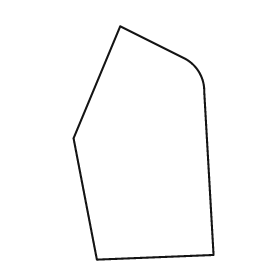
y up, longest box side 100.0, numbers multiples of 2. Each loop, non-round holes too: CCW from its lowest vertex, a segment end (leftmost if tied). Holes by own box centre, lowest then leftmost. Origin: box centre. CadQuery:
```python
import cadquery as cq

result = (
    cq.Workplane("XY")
    .moveTo(-20.0, -50.0)
    .lineTo(30.0, -48.0)
    .lineTo(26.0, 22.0)
    .threePointArc((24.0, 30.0), (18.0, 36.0))
    .lineTo(-10.0, 50.0)
    .lineTo(-30.0, 2.0)
    .close()
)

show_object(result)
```